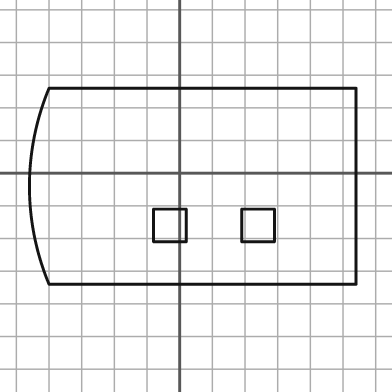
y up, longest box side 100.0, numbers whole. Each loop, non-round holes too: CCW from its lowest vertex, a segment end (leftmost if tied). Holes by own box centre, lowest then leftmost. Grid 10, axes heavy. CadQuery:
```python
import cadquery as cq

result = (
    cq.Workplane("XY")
    .moveTo(-40.0, -34.0)
    .lineTo(54.0, -34.0)
    .lineTo(54.0, 26.0)
    .lineTo(-40.0, 26.0)
    .threePointArc((-46.0, -4.0), (-40.0, -34.0))
    .close()
    .moveTo(-8.0, -21.0)
    .lineTo(2.0, -21.0)
    .lineTo(2.0, -11.0)
    .lineTo(-8.0, -11.0)
    .close()
    .moveTo(19.0, -21.0)
    .lineTo(29.0, -21.0)
    .lineTo(29.0, -11.0)
    .lineTo(19.0, -11.0)
    .close()
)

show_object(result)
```